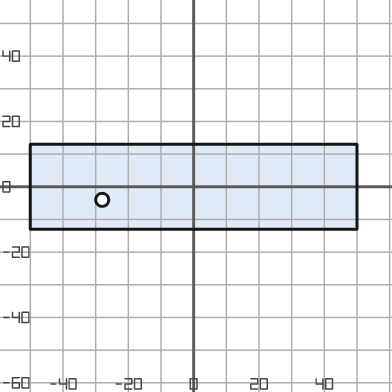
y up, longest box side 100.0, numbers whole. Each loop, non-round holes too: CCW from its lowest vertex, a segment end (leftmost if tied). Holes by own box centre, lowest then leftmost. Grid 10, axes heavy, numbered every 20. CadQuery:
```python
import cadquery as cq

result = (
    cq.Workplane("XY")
    .moveTo(-50.0, -13.0)
    .lineTo(50.0, -13.0)
    .lineTo(50.0, 13.0)
    .lineTo(-50.0, 13.0)
    .close()
    .moveTo(-28.0, -4.0)
    .circle(2.0)
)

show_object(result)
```